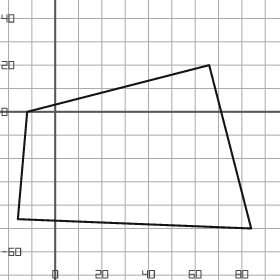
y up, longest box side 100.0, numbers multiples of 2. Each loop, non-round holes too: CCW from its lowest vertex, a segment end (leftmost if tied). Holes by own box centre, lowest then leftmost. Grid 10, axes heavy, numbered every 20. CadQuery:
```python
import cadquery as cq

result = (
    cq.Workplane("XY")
    .moveTo(84.0, -50.0)
    .lineTo(66.0, 20.0)
    .lineTo(-12.0, 0.0)
    .lineTo(-16.0, -46.0)
    .close()
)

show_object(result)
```